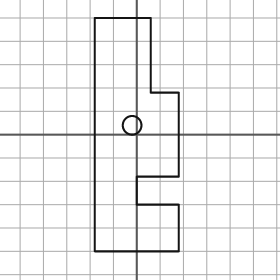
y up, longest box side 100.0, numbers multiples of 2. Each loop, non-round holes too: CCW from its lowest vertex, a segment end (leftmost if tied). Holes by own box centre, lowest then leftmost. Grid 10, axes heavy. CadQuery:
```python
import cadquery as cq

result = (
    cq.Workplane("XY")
    .moveTo(-18.0, -50.0)
    .lineTo(18.0, -50.0)
    .lineTo(18.0, -30.0)
    .lineTo(0.0, -30.0)
    .lineTo(0.0, -18.0)
    .lineTo(18.0, -18.0)
    .lineTo(18.0, 18.0)
    .lineTo(6.0, 18.0)
    .lineTo(6.0, 50.0)
    .lineTo(-18.0, 50.0)
    .close()
    .moveTo(-2.0, 4.0)
    .circle(4.0)
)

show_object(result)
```